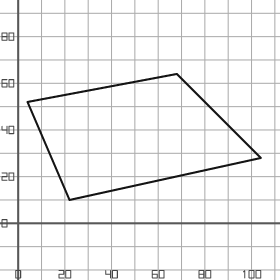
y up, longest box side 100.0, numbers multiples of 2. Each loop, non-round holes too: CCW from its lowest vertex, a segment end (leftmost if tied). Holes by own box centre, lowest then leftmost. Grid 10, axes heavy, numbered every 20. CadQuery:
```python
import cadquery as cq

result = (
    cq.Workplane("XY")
    .moveTo(22.0, 10.0)
    .lineTo(104.0, 28.0)
    .lineTo(68.0, 64.0)
    .lineTo(4.0, 52.0)
    .close()
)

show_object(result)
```